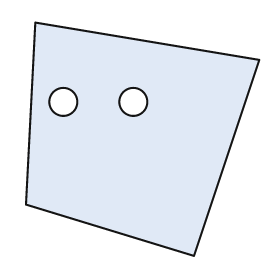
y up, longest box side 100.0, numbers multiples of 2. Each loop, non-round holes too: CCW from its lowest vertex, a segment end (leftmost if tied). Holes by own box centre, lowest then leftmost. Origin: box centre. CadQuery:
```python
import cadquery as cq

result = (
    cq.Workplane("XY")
    .moveTo(22.0, -50.0)
    .lineTo(50.0, 34.0)
    .lineTo(-46.0, 50.0)
    .lineTo(-50.0, -28.0)
    .close()
    .moveTo(-34.0, 16.0)
    .circle(6.0)
    .moveTo(-4.0, 16.0)
    .circle(6.0)
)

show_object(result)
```